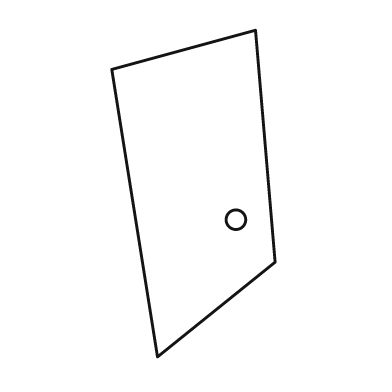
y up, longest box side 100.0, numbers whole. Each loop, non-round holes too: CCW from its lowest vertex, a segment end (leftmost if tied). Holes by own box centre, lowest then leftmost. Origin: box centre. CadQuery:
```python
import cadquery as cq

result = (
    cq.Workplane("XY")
    .moveTo(-11.0, -50.0)
    .lineTo(25.0, -21.0)
    .lineTo(19.0, 50.0)
    .lineTo(-25.0, 38.0)
    .close()
    .moveTo(13.0, -8.0)
    .circle(3.0)
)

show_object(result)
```